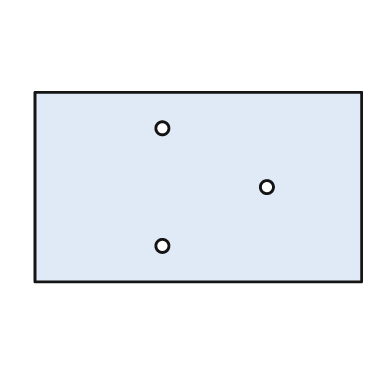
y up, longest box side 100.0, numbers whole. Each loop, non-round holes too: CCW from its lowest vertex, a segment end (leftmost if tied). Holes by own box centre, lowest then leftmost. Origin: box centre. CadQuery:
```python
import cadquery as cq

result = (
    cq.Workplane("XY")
    .moveTo(-50.0, -29.0)
    .lineTo(50.0, -29.0)
    .lineTo(50.0, 29.0)
    .lineTo(-50.0, 29.0)
    .close()
    .moveTo(-11.0, -18.0)
    .circle(2.0)
    .moveTo(21.0, 0.0)
    .circle(2.0)
    .moveTo(-11.0, 18.0)
    .circle(2.0)
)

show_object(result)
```